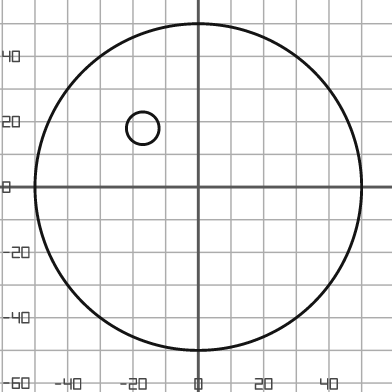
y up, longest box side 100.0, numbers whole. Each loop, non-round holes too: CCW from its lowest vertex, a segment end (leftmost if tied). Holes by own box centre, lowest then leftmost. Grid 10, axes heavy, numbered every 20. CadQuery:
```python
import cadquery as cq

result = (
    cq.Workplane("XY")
    .moveTo(0.0, 0.0)
    .circle(50.0)
    .moveTo(-17.0, 18.0)
    .circle(5.0)
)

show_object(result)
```